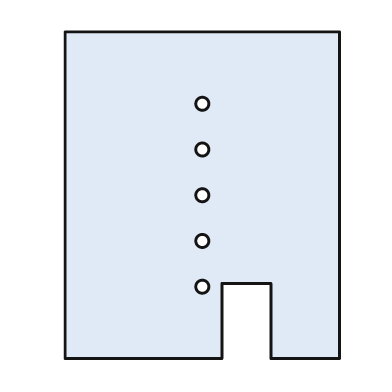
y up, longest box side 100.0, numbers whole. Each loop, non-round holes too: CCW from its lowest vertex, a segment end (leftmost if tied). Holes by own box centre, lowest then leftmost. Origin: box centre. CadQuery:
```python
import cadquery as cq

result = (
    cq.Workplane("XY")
    .moveTo(-42.0, -50.0)
    .lineTo(6.0, -50.0)
    .lineTo(6.0, -27.0)
    .lineTo(21.0, -27.0)
    .lineTo(21.0, -50.0)
    .lineTo(42.0, -50.0)
    .lineTo(42.0, 50.0)
    .lineTo(-42.0, 50.0)
    .close()
    .moveTo(0.0, -28.0)
    .circle(2.0)
    .moveTo(0.0, -14.0)
    .circle(2.0)
    .moveTo(0.0, 0.0)
    .circle(2.0)
    .moveTo(0.0, 14.0)
    .circle(2.0)
    .moveTo(0.0, 28.0)
    .circle(2.0)
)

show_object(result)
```